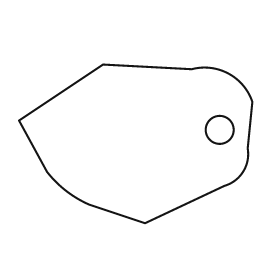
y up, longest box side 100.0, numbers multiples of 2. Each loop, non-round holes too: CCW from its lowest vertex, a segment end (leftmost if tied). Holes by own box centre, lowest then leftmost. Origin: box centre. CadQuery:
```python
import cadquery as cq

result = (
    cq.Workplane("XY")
    .moveTo(4.0, -34.0)
    .lineTo(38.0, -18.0)
    .threePointArc((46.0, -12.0), (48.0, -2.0))
    .lineTo(50.0, 18.0)
    .threePointArc((40.0, 30.0), (24.0, 32.0))
    .lineTo(-14.0, 34.0)
    .lineTo(-50.0, 10.0)
    .lineTo(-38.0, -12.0)
    .threePointArc((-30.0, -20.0), (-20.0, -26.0))
    .close()
    .moveTo(36.0, 6.0)
    .circle(6.0)
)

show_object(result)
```